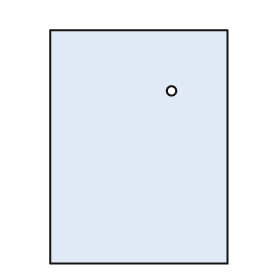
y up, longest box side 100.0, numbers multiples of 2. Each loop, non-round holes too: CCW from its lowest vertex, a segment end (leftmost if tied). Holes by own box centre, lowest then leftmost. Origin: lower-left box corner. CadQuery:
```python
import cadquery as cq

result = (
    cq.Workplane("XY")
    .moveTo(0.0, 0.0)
    .lineTo(76.0, 0.0)
    .lineTo(76.0, 100.0)
    .lineTo(0.0, 100.0)
    .close()
    .moveTo(52.0, 74.0)
    .circle(2.0)
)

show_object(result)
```